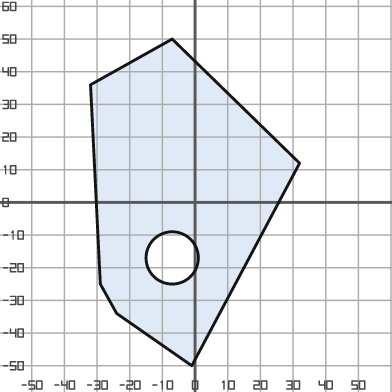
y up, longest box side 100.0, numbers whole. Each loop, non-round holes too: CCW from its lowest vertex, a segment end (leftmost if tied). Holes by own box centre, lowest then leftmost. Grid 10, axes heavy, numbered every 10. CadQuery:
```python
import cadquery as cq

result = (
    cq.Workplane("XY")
    .moveTo(-1.0, -50.0)
    .lineTo(32.0, 12.0)
    .lineTo(-7.0, 50.0)
    .lineTo(-32.0, 36.0)
    .lineTo(-29.0, -25.0)
    .lineTo(-24.0, -34.0)
    .close()
    .moveTo(-7.0, -17.0)
    .circle(8.0)
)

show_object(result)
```